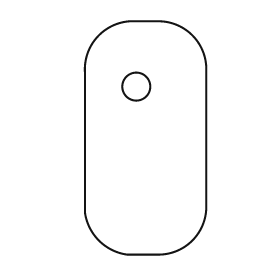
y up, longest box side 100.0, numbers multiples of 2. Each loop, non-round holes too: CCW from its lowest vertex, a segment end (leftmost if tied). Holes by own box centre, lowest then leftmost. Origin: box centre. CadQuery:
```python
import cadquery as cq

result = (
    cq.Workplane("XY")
    .moveTo(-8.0, -50.0)
    .lineTo(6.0, -50.0)
    .threePointArc((20.0, -44.0), (26.0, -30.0))
    .lineTo(26.0, 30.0)
    .threePointArc((20.0, 44.0), (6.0, 50.0))
    .lineTo(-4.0, 50.0)
    .threePointArc((-20.0, 44.0), (-26.0, 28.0))
    .lineTo(-26.0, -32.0)
    .threePointArc((-20.0, -44.0), (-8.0, -50.0))
    .close()
    .moveTo(-4.0, 22.0)
    .circle(6.0)
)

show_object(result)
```